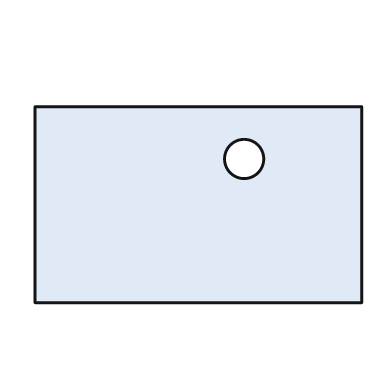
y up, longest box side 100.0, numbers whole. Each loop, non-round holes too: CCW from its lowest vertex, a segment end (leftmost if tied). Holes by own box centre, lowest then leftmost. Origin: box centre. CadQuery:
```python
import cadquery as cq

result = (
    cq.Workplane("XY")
    .moveTo(-50.0, -30.0)
    .lineTo(50.0, -30.0)
    .lineTo(50.0, 30.0)
    .lineTo(-50.0, 30.0)
    .close()
    .moveTo(14.0, 14.0)
    .circle(6.0)
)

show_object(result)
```